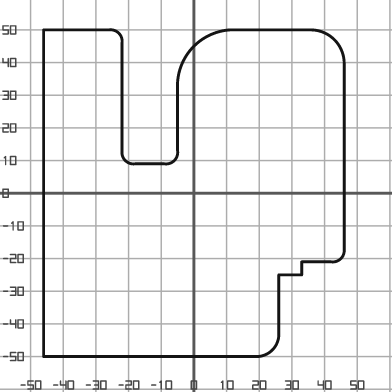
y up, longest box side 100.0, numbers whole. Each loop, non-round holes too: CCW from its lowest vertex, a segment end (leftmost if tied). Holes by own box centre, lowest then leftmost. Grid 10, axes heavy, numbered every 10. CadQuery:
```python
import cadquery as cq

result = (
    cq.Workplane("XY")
    .moveTo(-46.0, -50.0)
    .lineTo(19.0, -50.0)
    .threePointArc((24.0, -48.0), (26.0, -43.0))
    .lineTo(26.0, -25.0)
    .lineTo(33.0, -25.0)
    .lineTo(33.0, -21.0)
    .lineTo(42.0, -21.0)
    .threePointArc((45.0, -20.0), (46.0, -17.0))
    .lineTo(46.0, 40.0)
    .threePointArc((43.0, 47.0), (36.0, 50.0))
    .lineTo(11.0, 50.0)
    .threePointArc((0.0, 45.0), (-5.0, 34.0))
    .lineTo(-5.0, 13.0)
    .threePointArc((-6.0, 10.0), (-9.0, 9.0))
    .lineTo(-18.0, 9.0)
    .threePointArc((-21.0, 10.0), (-22.0, 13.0))
    .lineTo(-22.0, 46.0)
    .threePointArc((-23.0, 49.0), (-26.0, 50.0))
    .lineTo(-46.0, 50.0)
    .close()
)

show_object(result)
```